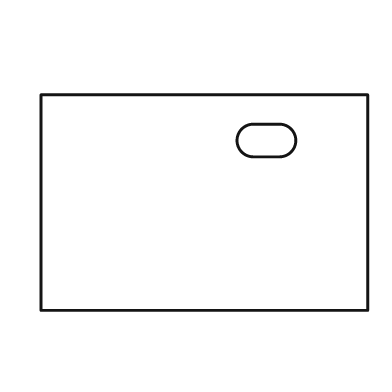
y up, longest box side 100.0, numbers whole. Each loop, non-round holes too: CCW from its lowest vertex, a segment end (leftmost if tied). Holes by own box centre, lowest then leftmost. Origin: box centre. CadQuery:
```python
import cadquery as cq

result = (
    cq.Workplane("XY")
    .moveTo(-50.0, -33.0)
    .lineTo(50.0, -33.0)
    .lineTo(50.0, 33.0)
    .lineTo(-50.0, 33.0)
    .close()
    .moveTo(15.0, 14.0)
    .lineTo(23.0, 14.0)
    .threePointArc((28.0, 19.0), (23.0, 24.0))
    .lineTo(15.0, 24.0)
    .threePointArc((10.0, 19.0), (15.0, 14.0))
    .close()
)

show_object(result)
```